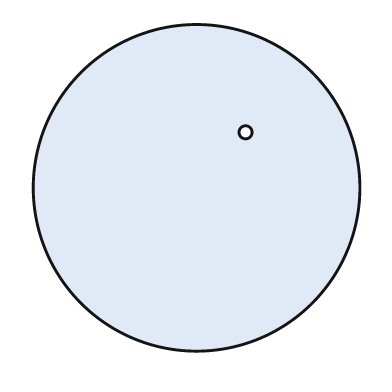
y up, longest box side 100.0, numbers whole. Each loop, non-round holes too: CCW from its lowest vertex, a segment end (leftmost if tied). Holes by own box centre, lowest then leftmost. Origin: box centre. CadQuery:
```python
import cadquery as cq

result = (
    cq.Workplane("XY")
    .moveTo(0.0, 0.0)
    .circle(50.0)
    .moveTo(15.0, 17.0)
    .circle(2.0)
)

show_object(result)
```